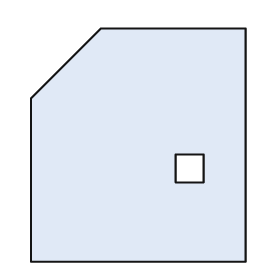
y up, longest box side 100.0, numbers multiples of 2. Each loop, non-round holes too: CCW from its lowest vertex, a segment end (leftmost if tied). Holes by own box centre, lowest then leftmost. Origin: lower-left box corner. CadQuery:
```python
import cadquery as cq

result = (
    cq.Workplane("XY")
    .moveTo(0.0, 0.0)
    .lineTo(92.0, 0.0)
    .lineTo(92.0, 100.0)
    .lineTo(30.0, 100.0)
    .lineTo(0.0, 70.0)
    .close()
    .moveTo(62.0, 34.0)
    .lineTo(74.0, 34.0)
    .lineTo(74.0, 46.0)
    .lineTo(62.0, 46.0)
    .close()
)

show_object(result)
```